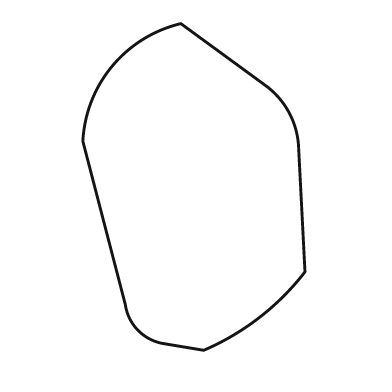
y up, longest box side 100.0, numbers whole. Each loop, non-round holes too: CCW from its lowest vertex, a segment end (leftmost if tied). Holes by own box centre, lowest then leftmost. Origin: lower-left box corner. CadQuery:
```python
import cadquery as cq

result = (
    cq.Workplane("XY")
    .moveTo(37.0, 0.0)
    .threePointArc((54.0, 10.0), (68.0, 24.0))
    .lineTo(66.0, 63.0)
    .threePointArc((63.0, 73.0), (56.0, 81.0))
    .lineTo(30.0, 100.0)
    .threePointArc((9.0, 87.0), (0.0, 64.0))
    .lineTo(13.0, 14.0)
    .threePointArc((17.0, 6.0), (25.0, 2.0))
    .close()
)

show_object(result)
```